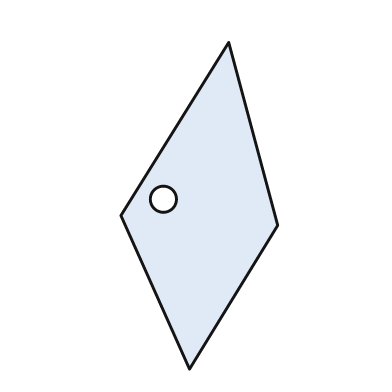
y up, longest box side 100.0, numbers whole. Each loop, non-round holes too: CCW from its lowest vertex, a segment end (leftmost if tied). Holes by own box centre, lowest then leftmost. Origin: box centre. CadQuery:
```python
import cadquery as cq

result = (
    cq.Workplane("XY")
    .moveTo(-3.0, -50.0)
    .lineTo(24.0, -6.0)
    .lineTo(9.0, 50.0)
    .lineTo(-24.0, -3.0)
    .close()
    .moveTo(-11.0, 2.0)
    .circle(4.0)
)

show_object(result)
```